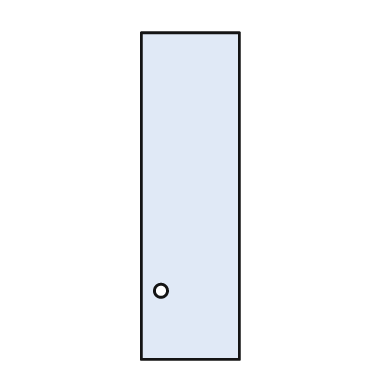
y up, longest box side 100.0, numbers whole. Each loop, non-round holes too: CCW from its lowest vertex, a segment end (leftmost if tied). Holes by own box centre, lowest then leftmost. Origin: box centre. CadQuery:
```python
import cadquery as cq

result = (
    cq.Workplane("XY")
    .moveTo(-15.0, -50.0)
    .lineTo(15.0, -50.0)
    .lineTo(15.0, 50.0)
    .lineTo(-15.0, 50.0)
    .close()
    .moveTo(-9.0, -29.0)
    .circle(2.0)
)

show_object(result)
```